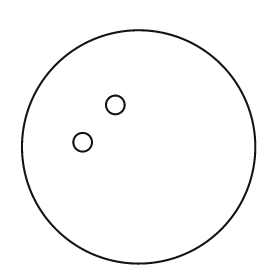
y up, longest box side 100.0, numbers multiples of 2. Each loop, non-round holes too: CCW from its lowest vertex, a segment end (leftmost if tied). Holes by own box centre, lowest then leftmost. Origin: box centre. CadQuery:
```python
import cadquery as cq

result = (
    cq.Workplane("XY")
    .moveTo(0.0, 0.0)
    .circle(50.0)
    .moveTo(-24.0, 2.0)
    .circle(4.0)
    .moveTo(-10.0, 18.0)
    .circle(4.0)
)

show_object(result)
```